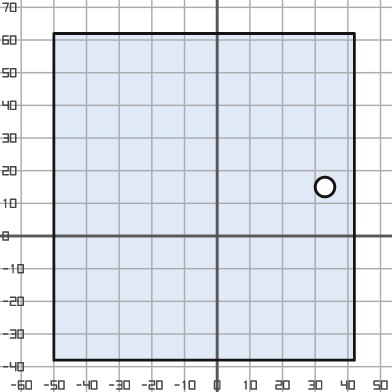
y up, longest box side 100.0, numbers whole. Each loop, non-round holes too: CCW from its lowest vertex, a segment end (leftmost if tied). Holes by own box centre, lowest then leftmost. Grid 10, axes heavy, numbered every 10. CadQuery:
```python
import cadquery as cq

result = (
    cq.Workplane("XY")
    .moveTo(-50.0, -38.0)
    .lineTo(42.0, -38.0)
    .lineTo(42.0, 62.0)
    .lineTo(-50.0, 62.0)
    .close()
    .moveTo(33.0, 15.0)
    .circle(3.0)
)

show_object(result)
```